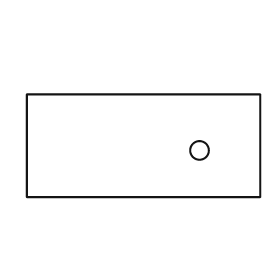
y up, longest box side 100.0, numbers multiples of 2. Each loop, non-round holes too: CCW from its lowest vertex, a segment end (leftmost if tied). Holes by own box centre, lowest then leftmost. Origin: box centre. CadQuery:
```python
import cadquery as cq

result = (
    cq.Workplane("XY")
    .moveTo(-50.0, -22.0)
    .lineTo(50.0, -22.0)
    .lineTo(50.0, 22.0)
    .lineTo(-50.0, 22.0)
    .close()
    .moveTo(24.0, -2.0)
    .circle(4.0)
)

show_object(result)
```